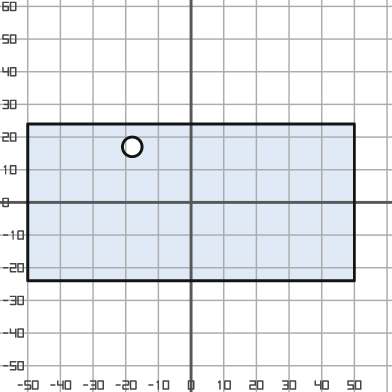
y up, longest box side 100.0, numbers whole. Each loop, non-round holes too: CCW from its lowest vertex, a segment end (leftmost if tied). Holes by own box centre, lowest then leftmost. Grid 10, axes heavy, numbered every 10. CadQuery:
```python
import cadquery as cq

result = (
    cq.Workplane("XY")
    .moveTo(-50.0, -24.0)
    .lineTo(50.0, -24.0)
    .lineTo(50.0, 24.0)
    .lineTo(-50.0, 24.0)
    .close()
    .moveTo(-18.0, 17.0)
    .circle(3.0)
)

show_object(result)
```